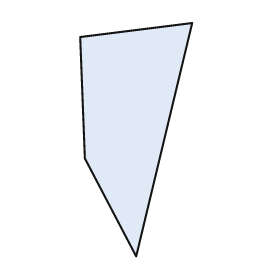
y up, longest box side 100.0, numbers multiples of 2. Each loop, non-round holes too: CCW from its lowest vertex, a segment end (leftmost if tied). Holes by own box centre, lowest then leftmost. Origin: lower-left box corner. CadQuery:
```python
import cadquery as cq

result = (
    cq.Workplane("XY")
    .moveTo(24.0, 0.0)
    .lineTo(48.0, 100.0)
    .lineTo(0.0, 94.0)
    .lineTo(2.0, 42.0)
    .close()
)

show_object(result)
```